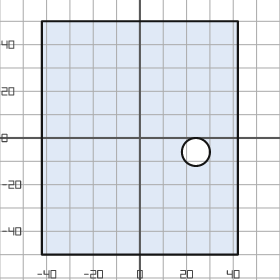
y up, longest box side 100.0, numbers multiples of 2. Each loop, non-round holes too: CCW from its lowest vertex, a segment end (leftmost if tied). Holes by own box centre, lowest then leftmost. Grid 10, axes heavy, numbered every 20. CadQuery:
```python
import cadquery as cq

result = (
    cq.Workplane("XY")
    .moveTo(-42.0, -50.0)
    .lineTo(42.0, -50.0)
    .lineTo(42.0, 50.0)
    .lineTo(-42.0, 50.0)
    .close()
    .moveTo(24.0, -6.0)
    .circle(6.0)
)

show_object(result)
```